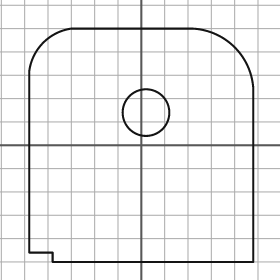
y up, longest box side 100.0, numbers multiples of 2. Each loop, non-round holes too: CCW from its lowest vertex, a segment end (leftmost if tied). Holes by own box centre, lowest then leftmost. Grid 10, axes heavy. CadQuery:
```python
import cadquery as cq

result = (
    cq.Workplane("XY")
    .moveTo(-38.0, -50.0)
    .lineTo(48.0, -50.0)
    .lineTo(48.0, 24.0)
    .threePointArc((40.0, 42.0), (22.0, 50.0))
    .lineTo(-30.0, 50.0)
    .threePointArc((-42.0, 44.0), (-48.0, 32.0))
    .lineTo(-48.0, -46.0)
    .lineTo(-38.0, -46.0)
    .close()
    .moveTo(2.0, 14.0)
    .circle(10.0)
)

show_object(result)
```